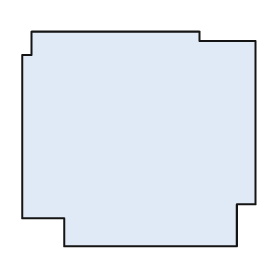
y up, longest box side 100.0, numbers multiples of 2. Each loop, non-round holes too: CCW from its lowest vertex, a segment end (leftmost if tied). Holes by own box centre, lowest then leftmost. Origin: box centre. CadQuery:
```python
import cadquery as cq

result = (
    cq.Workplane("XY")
    .moveTo(-32.0, -46.0)
    .lineTo(42.0, -46.0)
    .lineTo(42.0, -28.0)
    .lineTo(50.0, -28.0)
    .lineTo(50.0, 42.0)
    .lineTo(26.0, 42.0)
    .lineTo(26.0, 46.0)
    .lineTo(-46.0, 46.0)
    .lineTo(-46.0, 36.0)
    .lineTo(-50.0, 36.0)
    .lineTo(-50.0, -34.0)
    .lineTo(-32.0, -34.0)
    .close()
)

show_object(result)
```